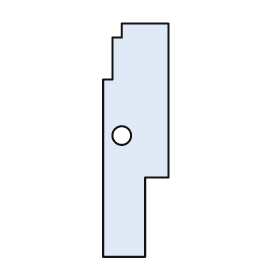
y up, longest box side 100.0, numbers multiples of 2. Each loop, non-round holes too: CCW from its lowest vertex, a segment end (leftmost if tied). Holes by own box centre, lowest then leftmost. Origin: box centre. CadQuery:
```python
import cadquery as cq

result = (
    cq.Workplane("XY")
    .moveTo(-14.0, -50.0)
    .lineTo(4.0, -50.0)
    .lineTo(4.0, -16.0)
    .lineTo(14.0, -16.0)
    .lineTo(14.0, 50.0)
    .lineTo(-6.0, 50.0)
    .lineTo(-6.0, 44.0)
    .lineTo(-10.0, 44.0)
    .lineTo(-10.0, 26.0)
    .lineTo(-14.0, 26.0)
    .close()
    .moveTo(-6.0, 2.0)
    .circle(4.0)
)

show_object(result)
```